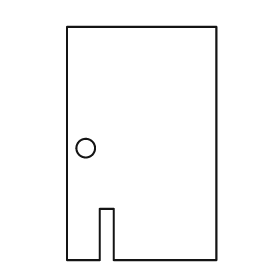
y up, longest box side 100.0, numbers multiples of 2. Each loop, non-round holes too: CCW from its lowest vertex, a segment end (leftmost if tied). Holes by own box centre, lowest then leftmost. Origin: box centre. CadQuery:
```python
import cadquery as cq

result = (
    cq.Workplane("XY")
    .moveTo(-32.0, -50.0)
    .lineTo(-18.0, -50.0)
    .lineTo(-18.0, -28.0)
    .lineTo(-12.0, -28.0)
    .lineTo(-12.0, -50.0)
    .lineTo(32.0, -50.0)
    .lineTo(32.0, 50.0)
    .lineTo(-32.0, 50.0)
    .close()
    .moveTo(-24.0, -2.0)
    .circle(4.0)
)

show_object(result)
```